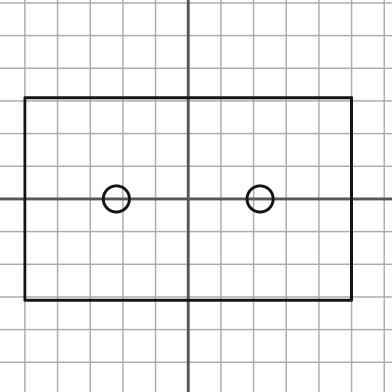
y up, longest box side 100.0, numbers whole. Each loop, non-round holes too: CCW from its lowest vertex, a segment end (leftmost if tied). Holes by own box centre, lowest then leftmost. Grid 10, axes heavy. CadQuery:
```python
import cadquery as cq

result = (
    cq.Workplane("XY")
    .moveTo(-50.0, -31.0)
    .lineTo(50.0, -31.0)
    .lineTo(50.0, 31.0)
    .lineTo(-50.0, 31.0)
    .close()
    .moveTo(-22.0, 0.0)
    .circle(4.0)
    .moveTo(22.0, 0.0)
    .circle(4.0)
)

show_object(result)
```